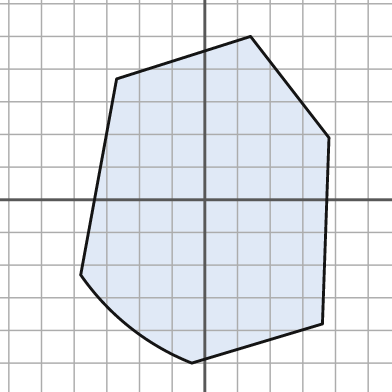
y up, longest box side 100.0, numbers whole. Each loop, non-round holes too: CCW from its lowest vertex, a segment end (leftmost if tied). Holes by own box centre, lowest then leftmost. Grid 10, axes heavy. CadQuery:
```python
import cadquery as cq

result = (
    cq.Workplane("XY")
    .moveTo(-4.0, -50.0)
    .lineTo(36.0, -38.0)
    .lineTo(38.0, 19.0)
    .lineTo(14.0, 50.0)
    .lineTo(-27.0, 37.0)
    .lineTo(-38.0, -23.0)
    .threePointArc((-23.0, -39.0), (-4.0, -50.0))
    .close()
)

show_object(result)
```